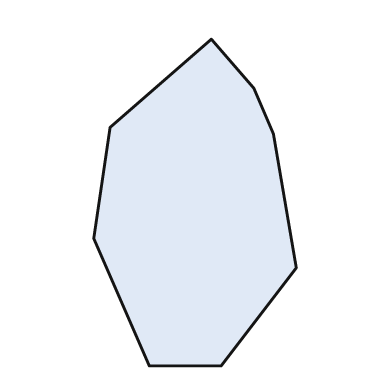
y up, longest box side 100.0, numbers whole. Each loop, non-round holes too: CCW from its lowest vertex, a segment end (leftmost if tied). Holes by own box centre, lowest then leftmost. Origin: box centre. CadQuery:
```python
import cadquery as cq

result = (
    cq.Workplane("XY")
    .moveTo(-14.0, -50.0)
    .lineTo(8.0, -50.0)
    .lineTo(31.0, -20.0)
    .lineTo(24.0, 21.0)
    .lineTo(18.0, 35.0)
    .lineTo(5.0, 50.0)
    .lineTo(-26.0, 23.0)
    .lineTo(-31.0, -11.0)
    .close()
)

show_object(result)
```